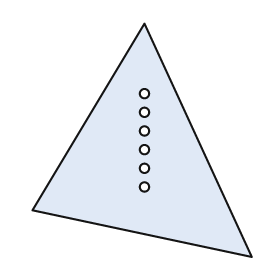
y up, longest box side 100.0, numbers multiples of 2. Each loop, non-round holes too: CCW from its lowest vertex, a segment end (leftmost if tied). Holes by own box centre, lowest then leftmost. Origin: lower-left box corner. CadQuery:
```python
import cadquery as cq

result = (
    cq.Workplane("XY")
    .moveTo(94.0, 0.0)
    .lineTo(48.0, 100.0)
    .lineTo(0.0, 20.0)
    .close()
    .moveTo(48.0, 30.0)
    .circle(2.0)
    .moveTo(48.0, 38.0)
    .circle(2.0)
    .moveTo(48.0, 46.0)
    .circle(2.0)
    .moveTo(48.0, 54.0)
    .circle(2.0)
    .moveTo(48.0, 62.0)
    .circle(2.0)
    .moveTo(48.0, 70.0)
    .circle(2.0)
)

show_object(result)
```